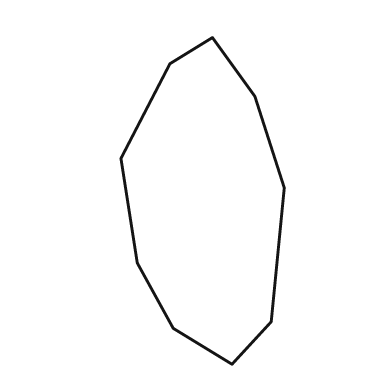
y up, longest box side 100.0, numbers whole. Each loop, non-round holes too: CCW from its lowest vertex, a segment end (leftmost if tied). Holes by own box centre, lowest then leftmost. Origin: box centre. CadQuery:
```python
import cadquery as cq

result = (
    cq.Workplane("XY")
    .moveTo(9.0, -50.0)
    .lineTo(21.0, -37.0)
    .lineTo(25.0, 4.0)
    .lineTo(16.0, 32.0)
    .lineTo(3.0, 50.0)
    .lineTo(-10.0, 42.0)
    .lineTo(-25.0, 13.0)
    .lineTo(-20.0, -19.0)
    .lineTo(-9.0, -39.0)
    .close()
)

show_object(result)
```